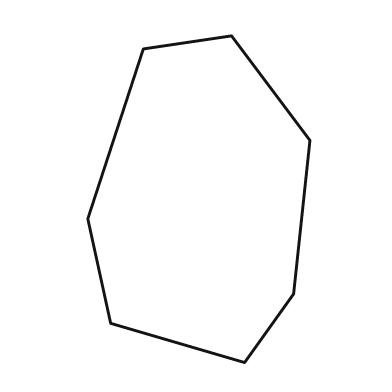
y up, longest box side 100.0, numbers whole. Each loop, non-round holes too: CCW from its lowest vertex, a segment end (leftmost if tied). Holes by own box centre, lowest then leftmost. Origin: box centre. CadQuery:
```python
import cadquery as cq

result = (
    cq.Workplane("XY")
    .moveTo(14.0, -50.0)
    .lineTo(29.0, -29.0)
    .lineTo(34.0, 18.0)
    .lineTo(10.0, 50.0)
    .lineTo(-17.0, 46.0)
    .lineTo(-34.0, -6.0)
    .lineTo(-27.0, -38.0)
    .close()
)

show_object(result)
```